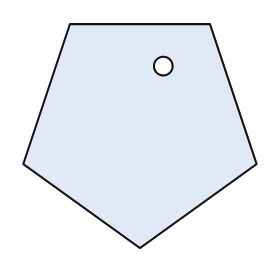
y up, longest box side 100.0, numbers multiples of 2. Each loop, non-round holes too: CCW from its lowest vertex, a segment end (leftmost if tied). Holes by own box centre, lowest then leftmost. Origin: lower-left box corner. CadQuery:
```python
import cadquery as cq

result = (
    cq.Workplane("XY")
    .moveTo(50.0, 0.0)
    .lineTo(100.0, 36.0)
    .lineTo(80.0, 96.0)
    .lineTo(20.0, 96.0)
    .lineTo(0.0, 36.0)
    .close()
    .moveTo(60.0, 78.0)
    .circle(4.0)
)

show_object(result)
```